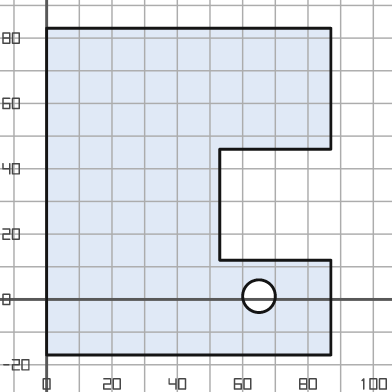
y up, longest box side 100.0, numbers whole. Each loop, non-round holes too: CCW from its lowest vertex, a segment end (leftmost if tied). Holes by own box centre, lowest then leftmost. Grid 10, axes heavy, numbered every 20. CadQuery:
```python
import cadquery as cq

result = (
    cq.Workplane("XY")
    .moveTo(0.0, -17.0)
    .lineTo(87.0, -17.0)
    .lineTo(87.0, 12.0)
    .lineTo(53.0, 12.0)
    .lineTo(53.0, 46.0)
    .lineTo(87.0, 46.0)
    .lineTo(87.0, 83.0)
    .lineTo(0.0, 83.0)
    .close()
    .moveTo(65.0, 1.0)
    .circle(5.0)
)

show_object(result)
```